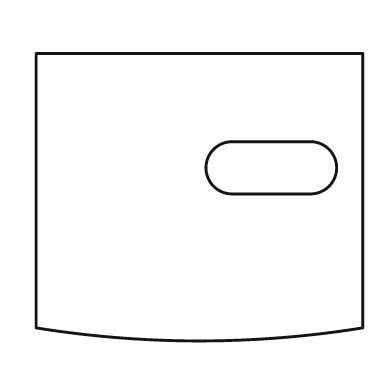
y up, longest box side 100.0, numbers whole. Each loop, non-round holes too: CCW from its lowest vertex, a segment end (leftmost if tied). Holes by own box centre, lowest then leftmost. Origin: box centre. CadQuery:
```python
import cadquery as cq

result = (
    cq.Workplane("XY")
    .moveTo(-50.0, -40.0)
    .threePointArc((0.0, -44.0), (50.0, -40.0))
    .lineTo(50.0, 44.0)
    .lineTo(-50.0, 44.0)
    .close()
    .moveTo(10.0, 1.0)
    .lineTo(34.0, 1.0)
    .threePointArc((42.0, 9.0), (34.0, 17.0))
    .lineTo(10.0, 17.0)
    .threePointArc((2.0, 9.0), (10.0, 1.0))
    .close()
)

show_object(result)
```